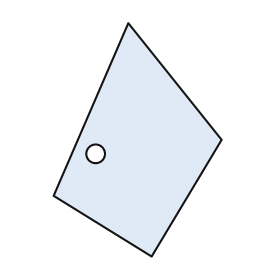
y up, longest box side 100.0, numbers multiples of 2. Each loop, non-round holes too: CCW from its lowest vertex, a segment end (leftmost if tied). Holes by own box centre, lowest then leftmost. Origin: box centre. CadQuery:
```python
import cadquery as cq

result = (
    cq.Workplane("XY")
    .moveTo(6.0, -50.0)
    .lineTo(36.0, 0.0)
    .lineTo(-4.0, 50.0)
    .lineTo(-36.0, -24.0)
    .close()
    .moveTo(-18.0, -6.0)
    .circle(4.0)
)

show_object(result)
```